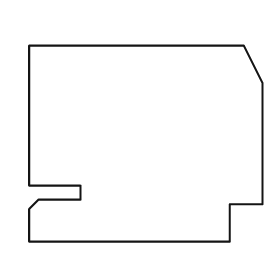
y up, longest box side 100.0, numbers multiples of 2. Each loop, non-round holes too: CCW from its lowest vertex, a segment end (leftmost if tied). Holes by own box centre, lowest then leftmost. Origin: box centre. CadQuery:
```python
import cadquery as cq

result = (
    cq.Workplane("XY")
    .moveTo(-50.0, -42.0)
    .lineTo(36.0, -42.0)
    .lineTo(36.0, -26.0)
    .lineTo(50.0, -26.0)
    .lineTo(50.0, 26.0)
    .lineTo(42.0, 42.0)
    .lineTo(-50.0, 42.0)
    .lineTo(-50.0, -18.0)
    .lineTo(-28.0, -18.0)
    .lineTo(-28.0, -24.0)
    .lineTo(-46.0, -24.0)
    .lineTo(-50.0, -28.0)
    .close()
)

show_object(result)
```